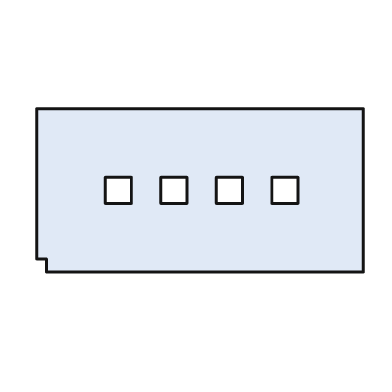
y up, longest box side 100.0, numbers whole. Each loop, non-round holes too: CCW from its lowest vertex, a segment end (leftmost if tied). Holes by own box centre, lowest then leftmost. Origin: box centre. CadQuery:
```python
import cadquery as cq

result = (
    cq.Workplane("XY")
    .moveTo(-47.0, -25.0)
    .lineTo(50.0, -25.0)
    .lineTo(50.0, 25.0)
    .lineTo(-50.0, 25.0)
    .lineTo(-50.0, -21.0)
    .lineTo(-47.0, -21.0)
    .close()
    .moveTo(-29.0, -4.0)
    .lineTo(-21.0, -4.0)
    .lineTo(-21.0, 4.0)
    .lineTo(-29.0, 4.0)
    .close()
    .moveTo(-12.0, -4.0)
    .lineTo(-4.0, -4.0)
    .lineTo(-4.0, 4.0)
    .lineTo(-12.0, 4.0)
    .close()
    .moveTo(5.0, -4.0)
    .lineTo(13.0, -4.0)
    .lineTo(13.0, 4.0)
    .lineTo(5.0, 4.0)
    .close()
    .moveTo(22.0, -4.0)
    .lineTo(30.0, -4.0)
    .lineTo(30.0, 4.0)
    .lineTo(22.0, 4.0)
    .close()
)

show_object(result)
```